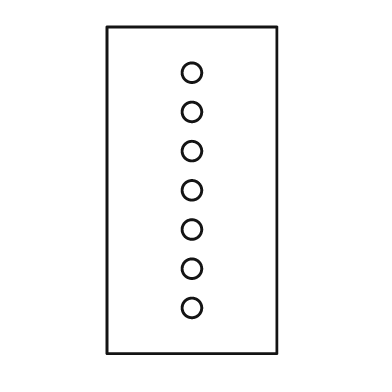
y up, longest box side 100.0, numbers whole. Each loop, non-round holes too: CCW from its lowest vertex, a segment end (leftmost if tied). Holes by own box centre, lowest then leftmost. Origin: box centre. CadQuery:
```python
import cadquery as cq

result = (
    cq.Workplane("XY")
    .moveTo(-26.0, -50.0)
    .lineTo(26.0, -50.0)
    .lineTo(26.0, 50.0)
    .lineTo(-26.0, 50.0)
    .close()
    .moveTo(0.0, -36.0)
    .circle(3.0)
    .moveTo(0.0, -24.0)
    .circle(3.0)
    .moveTo(0.0, -12.0)
    .circle(3.0)
    .moveTo(0.0, 0.0)
    .circle(3.0)
    .moveTo(0.0, 12.0)
    .circle(3.0)
    .moveTo(0.0, 24.0)
    .circle(3.0)
    .moveTo(0.0, 36.0)
    .circle(3.0)
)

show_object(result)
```